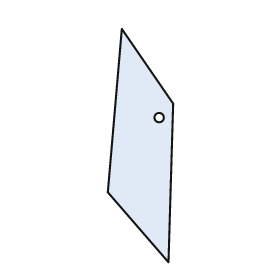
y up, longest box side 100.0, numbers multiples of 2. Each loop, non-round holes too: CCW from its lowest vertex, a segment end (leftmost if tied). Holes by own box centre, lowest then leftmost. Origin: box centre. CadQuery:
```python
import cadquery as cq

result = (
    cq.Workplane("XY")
    .moveTo(12.0, -50.0)
    .lineTo(14.0, 18.0)
    .lineTo(-8.0, 50.0)
    .lineTo(-14.0, -20.0)
    .close()
    .moveTo(8.0, 12.0)
    .circle(2.0)
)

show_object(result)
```